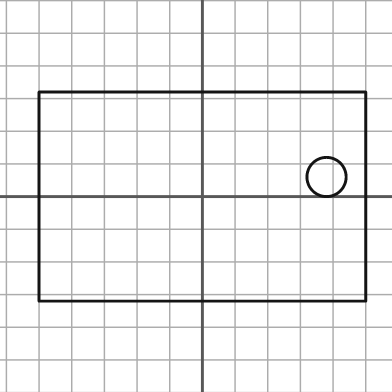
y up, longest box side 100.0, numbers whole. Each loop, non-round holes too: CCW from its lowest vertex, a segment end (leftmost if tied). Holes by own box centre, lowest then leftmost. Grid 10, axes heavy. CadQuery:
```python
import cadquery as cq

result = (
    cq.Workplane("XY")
    .moveTo(-50.0, -32.0)
    .lineTo(50.0, -32.0)
    .lineTo(50.0, 32.0)
    .lineTo(-50.0, 32.0)
    .close()
    .moveTo(38.0, 6.0)
    .circle(6.0)
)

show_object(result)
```